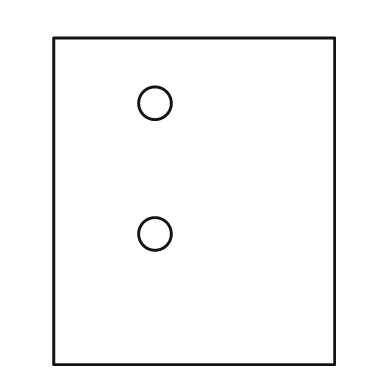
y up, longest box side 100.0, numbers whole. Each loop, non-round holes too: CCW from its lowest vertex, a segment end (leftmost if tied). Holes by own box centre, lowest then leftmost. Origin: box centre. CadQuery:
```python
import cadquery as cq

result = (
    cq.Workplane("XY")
    .moveTo(-43.0, -50.0)
    .lineTo(43.0, -50.0)
    .lineTo(43.0, 50.0)
    .lineTo(-43.0, 50.0)
    .close()
    .moveTo(-12.0, -10.0)
    .circle(5.0)
    .moveTo(-12.0, 30.0)
    .circle(5.0)
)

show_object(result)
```